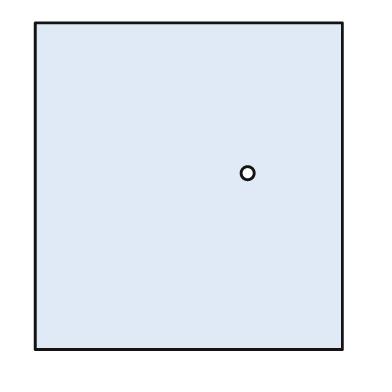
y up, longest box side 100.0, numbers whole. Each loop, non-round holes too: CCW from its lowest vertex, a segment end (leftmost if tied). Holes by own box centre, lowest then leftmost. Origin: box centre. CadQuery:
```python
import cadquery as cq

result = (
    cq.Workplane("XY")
    .moveTo(-47.0, -50.0)
    .lineTo(47.0, -50.0)
    .lineTo(47.0, 50.0)
    .lineTo(-47.0, 50.0)
    .close()
    .moveTo(18.0, 4.0)
    .circle(2.0)
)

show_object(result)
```